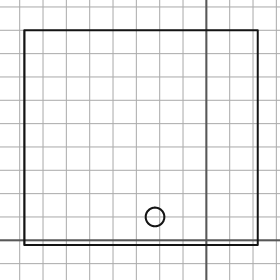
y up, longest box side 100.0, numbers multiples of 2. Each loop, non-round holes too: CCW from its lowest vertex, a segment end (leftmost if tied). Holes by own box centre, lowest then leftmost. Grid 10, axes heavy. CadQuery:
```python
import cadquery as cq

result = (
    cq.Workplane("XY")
    .moveTo(-78.0, -2.0)
    .lineTo(22.0, -2.0)
    .lineTo(22.0, 90.0)
    .lineTo(-78.0, 90.0)
    .close()
    .moveTo(-22.0, 10.0)
    .circle(4.0)
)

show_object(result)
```